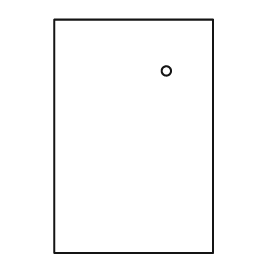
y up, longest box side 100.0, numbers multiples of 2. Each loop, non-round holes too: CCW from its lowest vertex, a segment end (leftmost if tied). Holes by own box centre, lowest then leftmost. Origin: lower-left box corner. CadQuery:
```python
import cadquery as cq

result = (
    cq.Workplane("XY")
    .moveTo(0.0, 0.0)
    .lineTo(68.0, 0.0)
    .lineTo(68.0, 100.0)
    .lineTo(0.0, 100.0)
    .close()
    .moveTo(48.0, 78.0)
    .circle(2.0)
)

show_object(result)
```